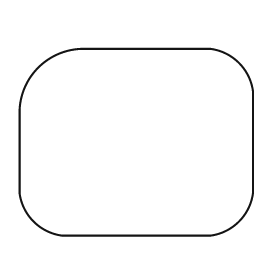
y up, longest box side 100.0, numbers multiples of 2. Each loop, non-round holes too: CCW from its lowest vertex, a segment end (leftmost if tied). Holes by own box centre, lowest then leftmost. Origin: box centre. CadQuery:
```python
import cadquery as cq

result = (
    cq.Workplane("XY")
    .moveTo(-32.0, -40.0)
    .lineTo(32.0, -40.0)
    .threePointArc((44.0, -34.0), (50.0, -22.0))
    .lineTo(50.0, 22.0)
    .threePointArc((44.0, 34.0), (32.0, 40.0))
    .lineTo(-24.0, 40.0)
    .threePointArc((-42.0, 32.0), (-50.0, 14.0))
    .lineTo(-50.0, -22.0)
    .threePointArc((-44.0, -34.0), (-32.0, -40.0))
    .close()
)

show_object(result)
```